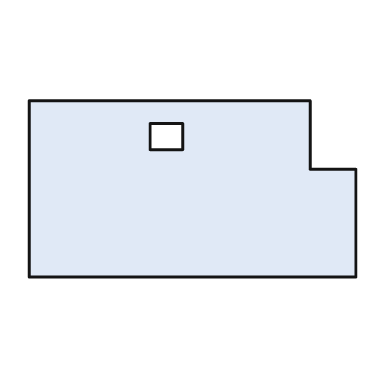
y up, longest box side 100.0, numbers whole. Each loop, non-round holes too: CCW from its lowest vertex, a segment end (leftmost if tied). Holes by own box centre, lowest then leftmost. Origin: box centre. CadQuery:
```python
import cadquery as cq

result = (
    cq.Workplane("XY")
    .moveTo(-50.0, -27.0)
    .lineTo(50.0, -27.0)
    .lineTo(50.0, 6.0)
    .lineTo(36.0, 6.0)
    .lineTo(36.0, 27.0)
    .lineTo(-50.0, 27.0)
    .close()
    .moveTo(-13.0, 12.0)
    .lineTo(-3.0, 12.0)
    .lineTo(-3.0, 20.0)
    .lineTo(-13.0, 20.0)
    .close()
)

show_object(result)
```